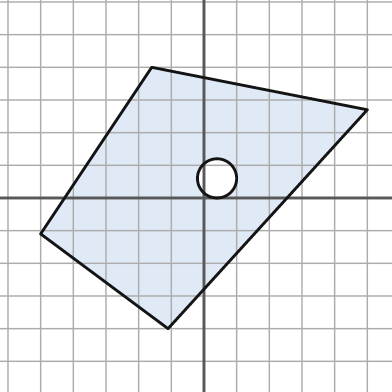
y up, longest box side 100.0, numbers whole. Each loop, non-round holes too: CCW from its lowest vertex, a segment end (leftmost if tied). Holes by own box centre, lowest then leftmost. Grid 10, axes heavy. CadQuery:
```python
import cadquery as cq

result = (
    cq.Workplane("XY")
    .moveTo(-11.0, -40.0)
    .lineTo(50.0, 27.0)
    .lineTo(-16.0, 40.0)
    .lineTo(-50.0, -11.0)
    .close()
    .moveTo(4.0, 6.0)
    .circle(6.0)
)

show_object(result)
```